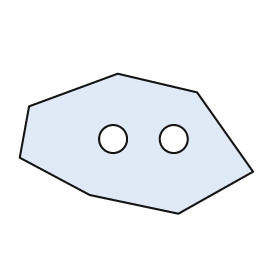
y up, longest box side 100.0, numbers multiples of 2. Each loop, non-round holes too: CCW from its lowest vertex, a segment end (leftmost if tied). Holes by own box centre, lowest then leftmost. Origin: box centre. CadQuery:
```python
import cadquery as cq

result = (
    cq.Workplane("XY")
    .moveTo(18.0, -30.0)
    .lineTo(50.0, -12.0)
    .lineTo(26.0, 22.0)
    .lineTo(-8.0, 30.0)
    .lineTo(-46.0, 16.0)
    .lineTo(-50.0, -6.0)
    .lineTo(-20.0, -22.0)
    .close()
    .moveTo(-10.0, 2.0)
    .circle(6.0)
    .moveTo(16.0, 2.0)
    .circle(6.0)
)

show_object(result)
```